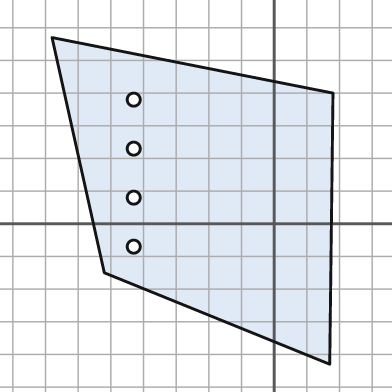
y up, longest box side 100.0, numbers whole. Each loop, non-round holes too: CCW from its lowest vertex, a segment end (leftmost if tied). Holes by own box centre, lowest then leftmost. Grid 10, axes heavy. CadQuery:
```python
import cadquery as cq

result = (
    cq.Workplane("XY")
    .moveTo(17.0, -43.0)
    .lineTo(18.0, 40.0)
    .lineTo(-68.0, 57.0)
    .lineTo(-52.0, -15.0)
    .close()
    .moveTo(-43.0, -7.0)
    .circle(2.0)
    .moveTo(-43.0, 8.0)
    .circle(2.0)
    .moveTo(-43.0, 23.0)
    .circle(2.0)
    .moveTo(-43.0, 38.0)
    .circle(2.0)
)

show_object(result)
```